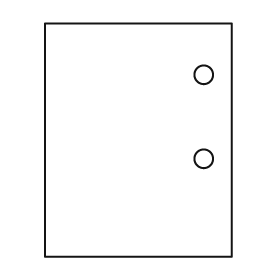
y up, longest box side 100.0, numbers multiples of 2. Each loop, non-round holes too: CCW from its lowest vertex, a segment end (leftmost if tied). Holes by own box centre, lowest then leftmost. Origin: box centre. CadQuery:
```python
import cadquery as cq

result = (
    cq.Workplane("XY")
    .moveTo(-40.0, -50.0)
    .lineTo(40.0, -50.0)
    .lineTo(40.0, 50.0)
    .lineTo(-40.0, 50.0)
    .close()
    .moveTo(28.0, -8.0)
    .circle(4.0)
    .moveTo(28.0, 28.0)
    .circle(4.0)
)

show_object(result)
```